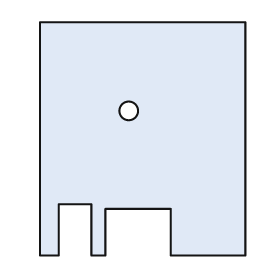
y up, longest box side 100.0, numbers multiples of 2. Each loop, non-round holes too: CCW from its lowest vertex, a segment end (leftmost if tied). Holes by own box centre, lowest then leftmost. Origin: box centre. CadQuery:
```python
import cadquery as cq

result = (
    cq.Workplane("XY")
    .moveTo(-44.0, -50.0)
    .lineTo(-36.0, -50.0)
    .lineTo(-36.0, -28.0)
    .lineTo(-22.0, -28.0)
    .lineTo(-22.0, -50.0)
    .lineTo(-16.0, -50.0)
    .lineTo(-16.0, -30.0)
    .lineTo(12.0, -30.0)
    .lineTo(12.0, -50.0)
    .lineTo(44.0, -50.0)
    .lineTo(44.0, 50.0)
    .lineTo(-44.0, 50.0)
    .close()
    .moveTo(-6.0, 12.0)
    .circle(4.0)
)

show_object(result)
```